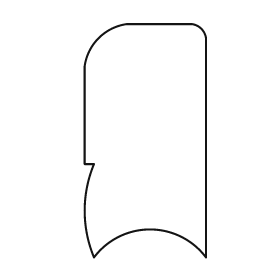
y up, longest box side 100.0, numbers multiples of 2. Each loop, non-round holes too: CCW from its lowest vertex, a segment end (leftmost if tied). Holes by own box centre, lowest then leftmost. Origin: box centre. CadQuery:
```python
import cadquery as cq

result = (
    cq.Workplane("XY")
    .moveTo(-22.0, -50.0)
    .threePointArc((2.0, -38.0), (26.0, -50.0))
    .lineTo(26.0, 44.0)
    .threePointArc((24.0, 48.0), (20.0, 50.0))
    .lineTo(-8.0, 50.0)
    .threePointArc((-20.0, 44.0), (-26.0, 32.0))
    .lineTo(-26.0, -10.0)
    .lineTo(-22.0, -10.0)
    .threePointArc((-26.0, -30.0), (-22.0, -50.0))
    .close()
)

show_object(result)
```